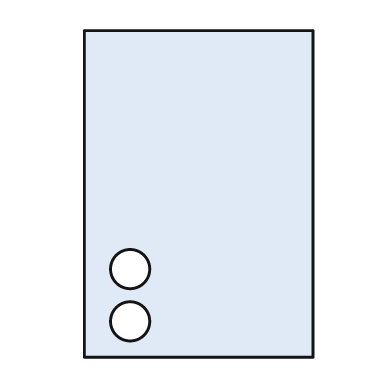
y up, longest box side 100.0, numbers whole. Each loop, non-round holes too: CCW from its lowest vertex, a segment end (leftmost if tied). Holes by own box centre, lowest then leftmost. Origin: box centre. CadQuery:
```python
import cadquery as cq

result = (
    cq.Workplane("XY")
    .moveTo(-35.0, -50.0)
    .lineTo(35.0, -50.0)
    .lineTo(35.0, 50.0)
    .lineTo(-35.0, 50.0)
    .close()
    .moveTo(-21.0, -39.0)
    .circle(6.0)
    .moveTo(-21.0, -23.0)
    .circle(6.0)
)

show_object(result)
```